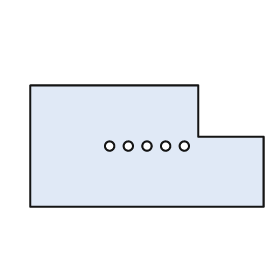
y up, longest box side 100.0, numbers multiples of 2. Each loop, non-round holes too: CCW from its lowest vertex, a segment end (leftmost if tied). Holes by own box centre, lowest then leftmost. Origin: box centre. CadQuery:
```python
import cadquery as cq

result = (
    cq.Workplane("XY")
    .moveTo(-50.0, -26.0)
    .lineTo(50.0, -26.0)
    .lineTo(50.0, 4.0)
    .lineTo(22.0, 4.0)
    .lineTo(22.0, 26.0)
    .lineTo(-50.0, 26.0)
    .close()
    .moveTo(-16.0, 0.0)
    .circle(2.0)
    .moveTo(-8.0, 0.0)
    .circle(2.0)
    .moveTo(0.0, 0.0)
    .circle(2.0)
    .moveTo(8.0, 0.0)
    .circle(2.0)
    .moveTo(16.0, 0.0)
    .circle(2.0)
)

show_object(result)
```